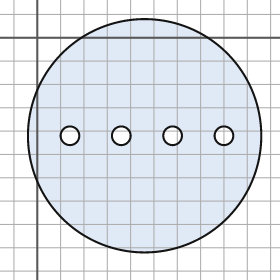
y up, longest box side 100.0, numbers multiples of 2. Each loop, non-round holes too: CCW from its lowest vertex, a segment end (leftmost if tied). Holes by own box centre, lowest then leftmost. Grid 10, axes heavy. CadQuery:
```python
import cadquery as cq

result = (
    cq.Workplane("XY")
    .moveTo(46.0, -42.0)
    .circle(50.0)
    .moveTo(14.0, -42.0)
    .circle(4.0)
    .moveTo(36.0, -42.0)
    .circle(4.0)
    .moveTo(58.0, -42.0)
    .circle(4.0)
    .moveTo(80.0, -42.0)
    .circle(4.0)
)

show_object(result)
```